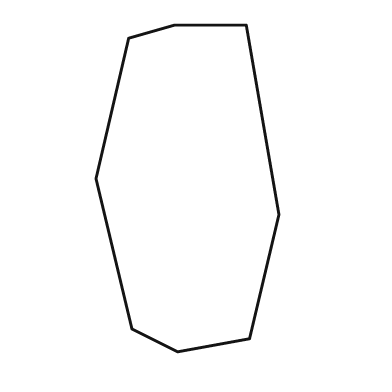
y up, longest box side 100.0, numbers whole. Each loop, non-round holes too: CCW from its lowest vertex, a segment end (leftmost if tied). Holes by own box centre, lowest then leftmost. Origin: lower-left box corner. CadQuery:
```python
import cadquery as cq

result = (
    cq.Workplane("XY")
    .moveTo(25.0, 0.0)
    .lineTo(47.0, 4.0)
    .lineTo(56.0, 42.0)
    .lineTo(46.0, 100.0)
    .lineTo(24.0, 100.0)
    .lineTo(10.0, 96.0)
    .lineTo(0.0, 53.0)
    .lineTo(11.0, 7.0)
    .close()
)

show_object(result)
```